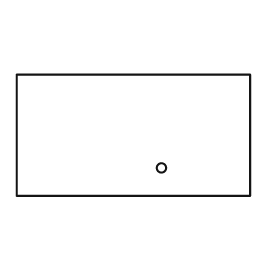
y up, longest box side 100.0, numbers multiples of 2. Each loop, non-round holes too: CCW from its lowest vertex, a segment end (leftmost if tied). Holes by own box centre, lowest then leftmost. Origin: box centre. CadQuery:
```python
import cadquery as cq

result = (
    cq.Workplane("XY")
    .moveTo(-50.0, -26.0)
    .lineTo(50.0, -26.0)
    .lineTo(50.0, 26.0)
    .lineTo(-50.0, 26.0)
    .close()
    .moveTo(12.0, -14.0)
    .circle(2.0)
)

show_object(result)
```